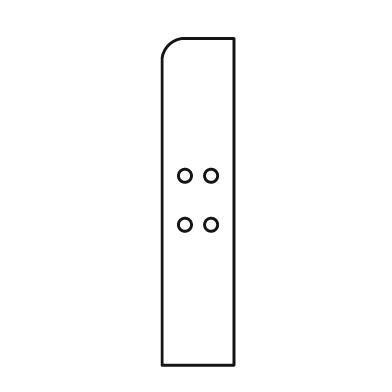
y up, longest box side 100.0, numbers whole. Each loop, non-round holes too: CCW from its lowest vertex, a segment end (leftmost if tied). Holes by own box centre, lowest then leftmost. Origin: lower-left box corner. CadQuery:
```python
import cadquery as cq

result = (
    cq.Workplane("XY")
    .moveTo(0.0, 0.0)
    .lineTo(22.0, 0.0)
    .lineTo(22.0, 100.0)
    .lineTo(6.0, 100.0)
    .threePointArc((2.0, 98.0), (0.0, 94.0))
    .close()
    .moveTo(7.0, 43.0)
    .circle(2.0)
    .moveTo(15.0, 43.0)
    .circle(2.0)
    .moveTo(7.0, 58.0)
    .circle(2.0)
    .moveTo(15.0, 58.0)
    .circle(2.0)
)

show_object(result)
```